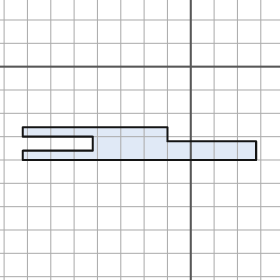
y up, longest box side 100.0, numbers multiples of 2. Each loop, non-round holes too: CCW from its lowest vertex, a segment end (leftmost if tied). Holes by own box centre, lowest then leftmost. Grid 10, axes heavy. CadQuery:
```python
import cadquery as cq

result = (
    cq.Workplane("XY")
    .moveTo(-72.0, -40.0)
    .lineTo(28.0, -40.0)
    .lineTo(28.0, -32.0)
    .lineTo(-10.0, -32.0)
    .lineTo(-10.0, -26.0)
    .lineTo(-72.0, -26.0)
    .lineTo(-72.0, -30.0)
    .lineTo(-42.0, -30.0)
    .lineTo(-42.0, -36.0)
    .lineTo(-72.0, -36.0)
    .close()
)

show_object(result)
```